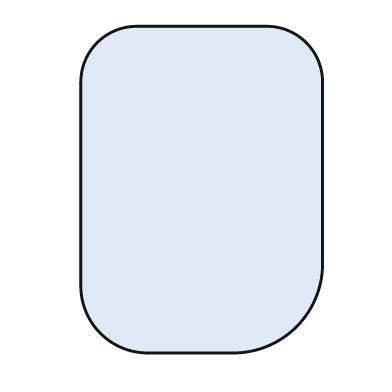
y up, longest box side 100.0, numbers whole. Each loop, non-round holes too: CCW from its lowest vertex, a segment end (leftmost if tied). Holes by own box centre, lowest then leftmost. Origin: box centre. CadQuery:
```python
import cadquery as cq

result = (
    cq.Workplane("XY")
    .moveTo(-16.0, -50.0)
    .lineTo(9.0, -50.0)
    .threePointArc((29.0, -42.0), (37.0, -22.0))
    .lineTo(37.0, 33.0)
    .threePointArc((32.0, 45.0), (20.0, 50.0))
    .lineTo(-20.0, 50.0)
    .threePointArc((-32.0, 45.0), (-37.0, 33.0))
    .lineTo(-37.0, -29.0)
    .threePointArc((-31.0, -44.0), (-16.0, -50.0))
    .close()
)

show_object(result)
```